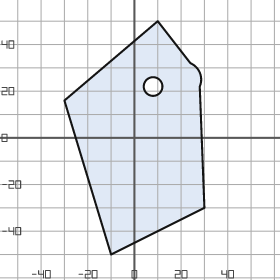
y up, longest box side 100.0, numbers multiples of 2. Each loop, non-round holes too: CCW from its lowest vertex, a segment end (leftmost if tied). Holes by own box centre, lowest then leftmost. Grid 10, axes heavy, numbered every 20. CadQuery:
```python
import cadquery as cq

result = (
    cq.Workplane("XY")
    .moveTo(-10.0, -50.0)
    .lineTo(30.0, -30.0)
    .lineTo(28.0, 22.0)
    .threePointArc((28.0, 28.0), (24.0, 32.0))
    .lineTo(10.0, 50.0)
    .lineTo(-30.0, 16.0)
    .close()
    .moveTo(8.0, 22.0)
    .circle(4.0)
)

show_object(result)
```